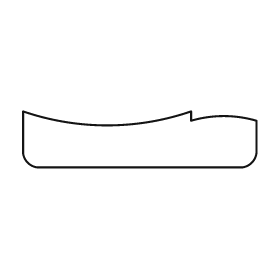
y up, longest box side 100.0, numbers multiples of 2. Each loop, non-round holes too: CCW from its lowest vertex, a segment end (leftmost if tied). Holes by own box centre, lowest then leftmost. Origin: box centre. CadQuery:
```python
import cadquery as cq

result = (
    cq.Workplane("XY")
    .moveTo(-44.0, -12.0)
    .lineTo(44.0, -12.0)
    .threePointArc((48.0, -10.0), (50.0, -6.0))
    .lineTo(50.0, 8.0)
    .threePointArc((36.0, 10.0), (22.0, 8.0))
    .lineTo(22.0, 12.0)
    .threePointArc((-14.0, 6.0), (-50.0, 12.0))
    .lineTo(-50.0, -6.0)
    .threePointArc((-48.0, -10.0), (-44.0, -12.0))
    .close()
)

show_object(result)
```